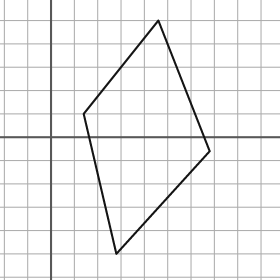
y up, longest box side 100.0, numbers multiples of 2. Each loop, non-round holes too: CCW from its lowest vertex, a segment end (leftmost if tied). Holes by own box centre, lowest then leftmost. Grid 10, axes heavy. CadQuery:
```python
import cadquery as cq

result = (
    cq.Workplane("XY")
    .moveTo(28.0, -50.0)
    .lineTo(68.0, -6.0)
    .lineTo(46.0, 50.0)
    .lineTo(14.0, 10.0)
    .close()
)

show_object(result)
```